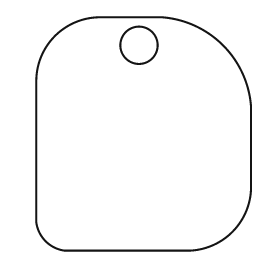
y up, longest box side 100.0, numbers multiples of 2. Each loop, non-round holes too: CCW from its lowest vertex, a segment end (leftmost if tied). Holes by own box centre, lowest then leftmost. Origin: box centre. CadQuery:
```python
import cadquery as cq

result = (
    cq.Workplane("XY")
    .moveTo(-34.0, -50.0)
    .lineTo(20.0, -50.0)
    .threePointArc((38.0, -42.0), (46.0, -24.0))
    .lineTo(46.0, 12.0)
    .threePointArc((34.0, 38.0), (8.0, 50.0))
    .lineTo(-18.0, 50.0)
    .threePointArc((-38.0, 42.0), (-46.0, 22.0))
    .lineTo(-46.0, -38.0)
    .threePointArc((-42.0, -46.0), (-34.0, -50.0))
    .close()
    .moveTo(-2.0, 38.0)
    .circle(8.0)
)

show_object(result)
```